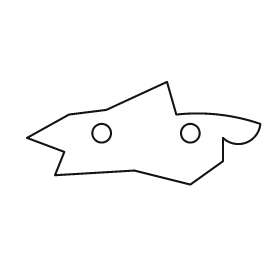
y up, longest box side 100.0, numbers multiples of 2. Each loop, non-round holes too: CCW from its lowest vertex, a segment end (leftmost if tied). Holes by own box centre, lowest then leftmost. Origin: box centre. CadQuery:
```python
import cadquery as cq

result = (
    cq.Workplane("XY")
    .moveTo(20.0, -22.0)
    .lineTo(34.0, -12.0)
    .lineTo(34.0, -2.0)
    .threePointArc((44.0, -4.0), (50.0, 4.0))
    .threePointArc((32.0, 8.0), (14.0, 8.0))
    .lineTo(10.0, 22.0)
    .lineTo(-16.0, 10.0)
    .lineTo(-32.0, 8.0)
    .lineTo(-50.0, -2.0)
    .lineTo(-34.0, -8.0)
    .lineTo(-38.0, -18.0)
    .lineTo(-4.0, -16.0)
    .close()
    .moveTo(-18.0, 0.0)
    .circle(4.0)
    .moveTo(20.0, 0.0)
    .circle(4.0)
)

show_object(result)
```